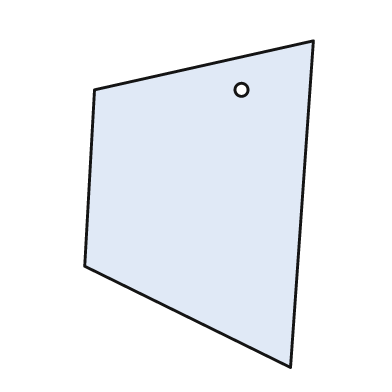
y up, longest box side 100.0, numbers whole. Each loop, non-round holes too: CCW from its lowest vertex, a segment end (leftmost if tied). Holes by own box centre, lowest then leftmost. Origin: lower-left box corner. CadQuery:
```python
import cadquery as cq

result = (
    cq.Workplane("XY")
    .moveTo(63.0, 0.0)
    .lineTo(70.0, 100.0)
    .lineTo(3.0, 85.0)
    .lineTo(0.0, 31.0)
    .close()
    .moveTo(48.0, 85.0)
    .circle(2.0)
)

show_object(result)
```